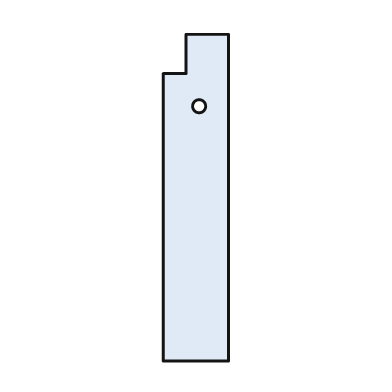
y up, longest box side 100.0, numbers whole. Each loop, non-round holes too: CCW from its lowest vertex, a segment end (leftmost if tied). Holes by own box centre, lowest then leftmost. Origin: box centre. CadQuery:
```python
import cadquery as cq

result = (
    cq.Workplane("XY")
    .moveTo(-10.0, -50.0)
    .lineTo(10.0, -50.0)
    .lineTo(10.0, 50.0)
    .lineTo(-3.0, 50.0)
    .lineTo(-3.0, 38.0)
    .lineTo(-10.0, 38.0)
    .close()
    .moveTo(1.0, 28.0)
    .circle(2.0)
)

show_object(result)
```